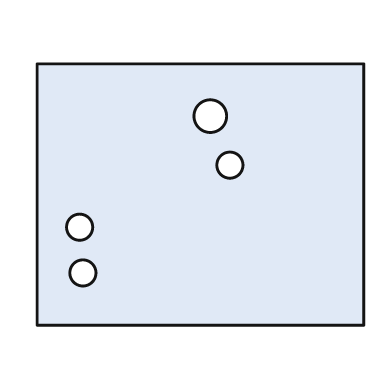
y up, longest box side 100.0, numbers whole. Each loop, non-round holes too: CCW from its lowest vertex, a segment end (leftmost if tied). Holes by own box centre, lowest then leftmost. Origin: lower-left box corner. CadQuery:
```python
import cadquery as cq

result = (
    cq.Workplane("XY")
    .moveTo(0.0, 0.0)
    .lineTo(100.0, 0.0)
    .lineTo(100.0, 80.0)
    .lineTo(0.0, 80.0)
    .close()
    .moveTo(14.0, 16.0)
    .circle(4.0)
    .moveTo(13.0, 30.0)
    .circle(4.0)
    .moveTo(59.0, 49.0)
    .circle(4.0)
    .moveTo(53.0, 64.0)
    .circle(5.0)
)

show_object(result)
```